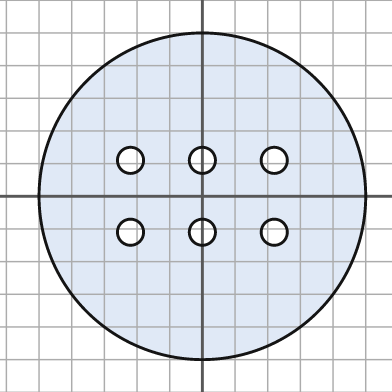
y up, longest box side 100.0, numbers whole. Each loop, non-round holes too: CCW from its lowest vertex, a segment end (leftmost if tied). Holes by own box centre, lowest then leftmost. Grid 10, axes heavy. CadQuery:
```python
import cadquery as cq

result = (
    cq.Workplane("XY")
    .moveTo(0.0, 0.0)
    .circle(50.0)
    .moveTo(-22.0, -11.0)
    .circle(4.0)
    .moveTo(0.0, -11.0)
    .circle(4.0)
    .moveTo(22.0, -11.0)
    .circle(4.0)
    .moveTo(-22.0, 11.0)
    .circle(4.0)
    .moveTo(0.0, 11.0)
    .circle(4.0)
    .moveTo(22.0, 11.0)
    .circle(4.0)
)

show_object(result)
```